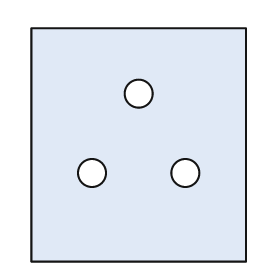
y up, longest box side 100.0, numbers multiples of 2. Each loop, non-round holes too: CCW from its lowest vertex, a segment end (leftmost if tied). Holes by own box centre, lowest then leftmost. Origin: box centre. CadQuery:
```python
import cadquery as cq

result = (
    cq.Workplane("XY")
    .moveTo(-46.0, -50.0)
    .lineTo(46.0, -50.0)
    .lineTo(46.0, 50.0)
    .lineTo(-46.0, 50.0)
    .close()
    .moveTo(-20.0, -12.0)
    .circle(6.0)
    .moveTo(20.0, -12.0)
    .circle(6.0)
    .moveTo(0.0, 22.0)
    .circle(6.0)
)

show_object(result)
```